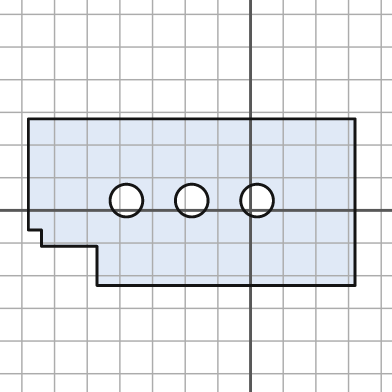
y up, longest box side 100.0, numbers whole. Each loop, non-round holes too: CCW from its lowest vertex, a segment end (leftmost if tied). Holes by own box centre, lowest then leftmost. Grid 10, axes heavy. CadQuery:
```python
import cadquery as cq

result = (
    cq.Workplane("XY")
    .moveTo(-47.0, -23.0)
    .lineTo(32.0, -23.0)
    .lineTo(32.0, 28.0)
    .lineTo(-68.0, 28.0)
    .lineTo(-68.0, -6.0)
    .lineTo(-64.0, -6.0)
    .lineTo(-64.0, -11.0)
    .lineTo(-47.0, -11.0)
    .close()
    .moveTo(-38.0, 3.0)
    .circle(5.0)
    .moveTo(-18.0, 3.0)
    .circle(5.0)
    .moveTo(2.0, 3.0)
    .circle(5.0)
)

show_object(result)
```